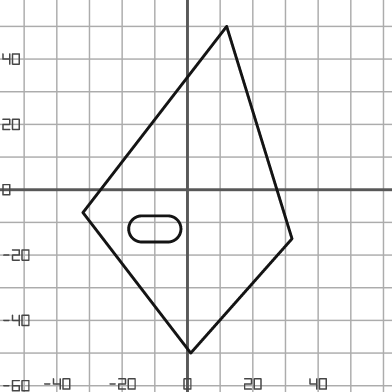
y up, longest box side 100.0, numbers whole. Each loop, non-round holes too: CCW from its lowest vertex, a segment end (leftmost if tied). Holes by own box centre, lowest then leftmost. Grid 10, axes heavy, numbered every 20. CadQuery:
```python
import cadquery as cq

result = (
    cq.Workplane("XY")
    .moveTo(1.0, -50.0)
    .lineTo(32.0, -15.0)
    .lineTo(12.0, 50.0)
    .lineTo(-32.0, -7.0)
    .close()
    .moveTo(-14.0, -16.0)
    .lineTo(-6.0, -16.0)
    .threePointArc((-2.0, -12.0), (-6.0, -8.0))
    .lineTo(-14.0, -8.0)
    .threePointArc((-18.0, -12.0), (-14.0, -16.0))
    .close()
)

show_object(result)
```